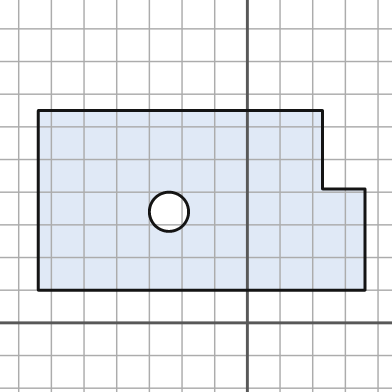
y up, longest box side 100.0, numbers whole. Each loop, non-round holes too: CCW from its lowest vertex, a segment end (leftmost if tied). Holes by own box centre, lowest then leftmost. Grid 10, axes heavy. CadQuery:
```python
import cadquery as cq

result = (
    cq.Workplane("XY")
    .moveTo(-64.0, 10.0)
    .lineTo(36.0, 10.0)
    .lineTo(36.0, 41.0)
    .lineTo(23.0, 41.0)
    .lineTo(23.0, 65.0)
    .lineTo(-64.0, 65.0)
    .close()
    .moveTo(-24.0, 34.0)
    .circle(6.0)
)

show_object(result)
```